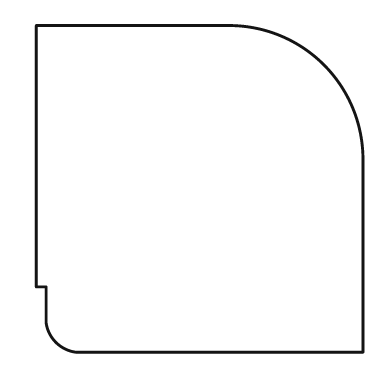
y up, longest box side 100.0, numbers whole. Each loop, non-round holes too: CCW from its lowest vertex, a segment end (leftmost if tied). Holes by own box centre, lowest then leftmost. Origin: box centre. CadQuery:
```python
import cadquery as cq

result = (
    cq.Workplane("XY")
    .moveTo(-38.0, -50.0)
    .lineTo(50.0, -50.0)
    .lineTo(50.0, 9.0)
    .threePointArc((38.0, 38.0), (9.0, 50.0))
    .lineTo(-50.0, 50.0)
    .lineTo(-50.0, -30.0)
    .lineTo(-47.0, -30.0)
    .lineTo(-47.0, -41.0)
    .threePointArc((-44.0, -47.0), (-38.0, -50.0))
    .close()
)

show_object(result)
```